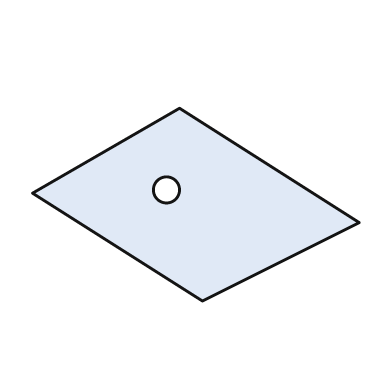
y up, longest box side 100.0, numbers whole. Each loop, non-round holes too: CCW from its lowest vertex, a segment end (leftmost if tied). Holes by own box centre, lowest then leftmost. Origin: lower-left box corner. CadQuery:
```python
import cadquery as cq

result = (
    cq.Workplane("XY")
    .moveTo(52.0, 0.0)
    .lineTo(100.0, 24.0)
    .lineTo(45.0, 59.0)
    .lineTo(0.0, 33.0)
    .close()
    .moveTo(41.0, 34.0)
    .circle(4.0)
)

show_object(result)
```